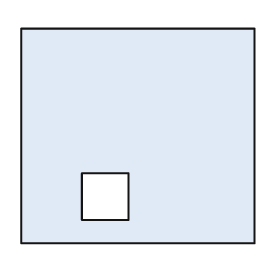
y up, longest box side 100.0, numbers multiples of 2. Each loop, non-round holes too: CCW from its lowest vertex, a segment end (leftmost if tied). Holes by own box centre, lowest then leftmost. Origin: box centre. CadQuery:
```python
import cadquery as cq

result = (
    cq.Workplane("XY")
    .moveTo(-50.0, -46.0)
    .lineTo(50.0, -46.0)
    .lineTo(50.0, 46.0)
    .lineTo(-50.0, 46.0)
    .close()
    .moveTo(-24.0, -36.0)
    .lineTo(-4.0, -36.0)
    .lineTo(-4.0, -16.0)
    .lineTo(-24.0, -16.0)
    .close()
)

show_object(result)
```